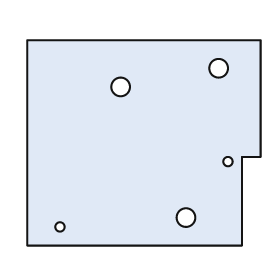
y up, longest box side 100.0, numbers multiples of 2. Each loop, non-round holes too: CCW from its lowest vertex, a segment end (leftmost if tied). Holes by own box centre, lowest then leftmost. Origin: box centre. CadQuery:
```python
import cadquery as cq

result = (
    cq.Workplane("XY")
    .moveTo(-50.0, -44.0)
    .lineTo(42.0, -44.0)
    .lineTo(42.0, -6.0)
    .lineTo(50.0, -6.0)
    .lineTo(50.0, 44.0)
    .lineTo(-50.0, 44.0)
    .close()
    .moveTo(-36.0, -36.0)
    .circle(2.0)
    .moveTo(18.0, -32.0)
    .circle(4.0)
    .moveTo(36.0, -8.0)
    .circle(2.0)
    .moveTo(-10.0, 24.0)
    .circle(4.0)
    .moveTo(32.0, 32.0)
    .circle(4.0)
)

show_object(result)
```